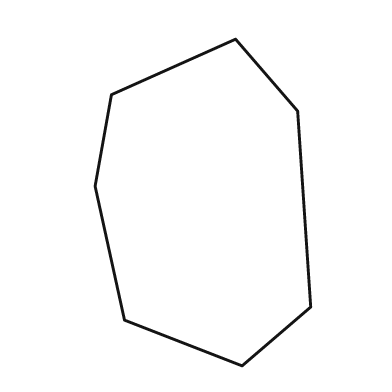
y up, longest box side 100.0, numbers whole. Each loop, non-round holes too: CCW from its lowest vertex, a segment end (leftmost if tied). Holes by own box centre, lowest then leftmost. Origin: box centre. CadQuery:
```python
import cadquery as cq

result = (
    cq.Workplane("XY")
    .moveTo(12.0, -50.0)
    .lineTo(33.0, -32.0)
    .lineTo(29.0, 28.0)
    .lineTo(10.0, 50.0)
    .lineTo(-28.0, 33.0)
    .lineTo(-33.0, 5.0)
    .lineTo(-24.0, -36.0)
    .close()
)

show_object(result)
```